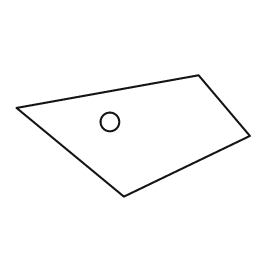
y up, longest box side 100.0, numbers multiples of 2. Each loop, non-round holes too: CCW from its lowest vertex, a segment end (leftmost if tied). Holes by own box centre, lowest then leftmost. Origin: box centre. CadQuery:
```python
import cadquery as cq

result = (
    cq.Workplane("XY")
    .moveTo(-4.0, -26.0)
    .lineTo(50.0, 0.0)
    .lineTo(28.0, 26.0)
    .lineTo(-50.0, 12.0)
    .close()
    .moveTo(-10.0, 6.0)
    .circle(4.0)
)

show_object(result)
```